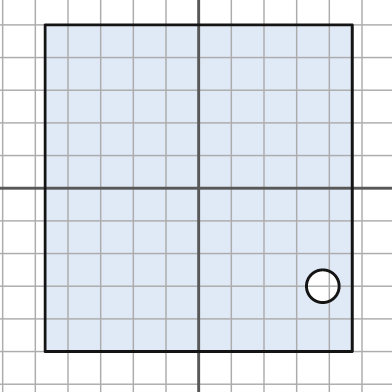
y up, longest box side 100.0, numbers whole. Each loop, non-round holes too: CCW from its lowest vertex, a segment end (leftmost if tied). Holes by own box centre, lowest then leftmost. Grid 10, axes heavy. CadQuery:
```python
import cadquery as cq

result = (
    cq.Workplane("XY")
    .moveTo(-47.0, -50.0)
    .lineTo(47.0, -50.0)
    .lineTo(47.0, 50.0)
    .lineTo(-47.0, 50.0)
    .close()
    .moveTo(38.0, -30.0)
    .circle(5.0)
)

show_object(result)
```